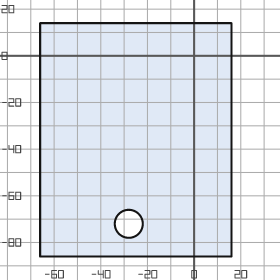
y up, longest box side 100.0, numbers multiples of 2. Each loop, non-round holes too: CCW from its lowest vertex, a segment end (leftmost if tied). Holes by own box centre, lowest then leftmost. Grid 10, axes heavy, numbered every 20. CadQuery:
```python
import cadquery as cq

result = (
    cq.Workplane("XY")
    .moveTo(-66.0, -86.0)
    .lineTo(16.0, -86.0)
    .lineTo(16.0, 14.0)
    .lineTo(-66.0, 14.0)
    .close()
    .moveTo(-28.0, -72.0)
    .circle(6.0)
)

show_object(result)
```